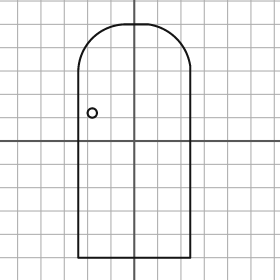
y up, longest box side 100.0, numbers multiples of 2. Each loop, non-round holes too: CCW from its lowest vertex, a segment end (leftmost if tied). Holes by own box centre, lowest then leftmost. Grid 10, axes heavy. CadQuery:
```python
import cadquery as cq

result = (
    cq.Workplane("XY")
    .moveTo(-24.0, -50.0)
    .lineTo(24.0, -50.0)
    .lineTo(24.0, 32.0)
    .threePointArc((18.0, 44.0), (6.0, 50.0))
    .lineTo(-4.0, 50.0)
    .threePointArc((-18.0, 44.0), (-24.0, 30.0))
    .close()
    .moveTo(-18.0, 12.0)
    .circle(2.0)
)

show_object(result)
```